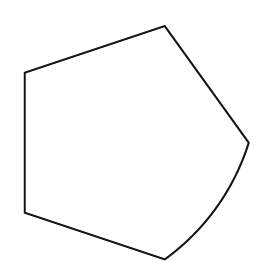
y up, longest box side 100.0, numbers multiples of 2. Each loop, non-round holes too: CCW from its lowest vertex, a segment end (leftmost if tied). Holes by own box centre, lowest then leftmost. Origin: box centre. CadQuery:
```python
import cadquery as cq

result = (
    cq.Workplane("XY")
    .moveTo(12.0, -50.0)
    .threePointArc((34.0, -28.0), (48.0, 0.0))
    .lineTo(12.0, 50.0)
    .lineTo(-48.0, 30.0)
    .lineTo(-48.0, -30.0)
    .close()
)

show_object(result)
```